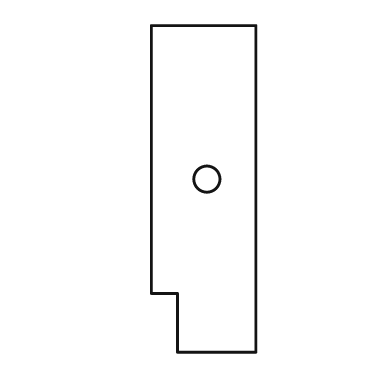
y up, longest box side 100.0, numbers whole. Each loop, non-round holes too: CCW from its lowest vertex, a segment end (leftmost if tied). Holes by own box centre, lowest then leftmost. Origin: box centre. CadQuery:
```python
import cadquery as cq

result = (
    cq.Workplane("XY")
    .moveTo(-8.0, -50.0)
    .lineTo(16.0, -50.0)
    .lineTo(16.0, 50.0)
    .lineTo(-16.0, 50.0)
    .lineTo(-16.0, -32.0)
    .lineTo(-8.0, -32.0)
    .close()
    .moveTo(1.0, 3.0)
    .circle(4.0)
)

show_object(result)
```